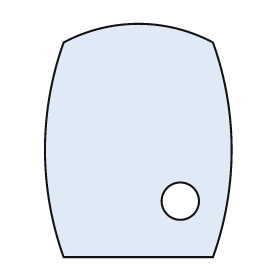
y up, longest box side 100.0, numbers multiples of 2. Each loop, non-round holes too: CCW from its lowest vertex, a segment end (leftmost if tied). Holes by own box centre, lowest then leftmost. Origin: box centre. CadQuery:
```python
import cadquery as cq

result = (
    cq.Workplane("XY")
    .moveTo(-32.0, -50.0)
    .lineTo(32.0, -50.0)
    .threePointArc((40.0, -4.0), (32.0, 42.0))
    .threePointArc((0.0, 50.0), (-32.0, 42.0))
    .threePointArc((-40.0, -4.0), (-32.0, -50.0))
    .close()
    .moveTo(18.0, -26.0)
    .circle(8.0)
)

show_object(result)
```